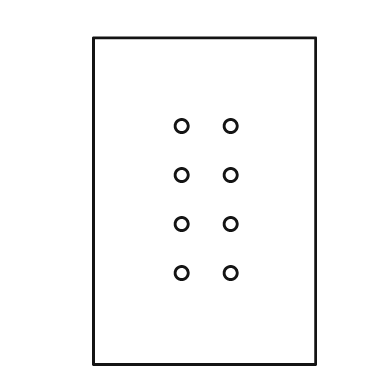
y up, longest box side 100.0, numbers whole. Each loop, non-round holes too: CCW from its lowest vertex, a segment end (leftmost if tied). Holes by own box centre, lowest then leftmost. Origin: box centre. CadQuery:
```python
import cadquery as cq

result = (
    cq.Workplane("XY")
    .moveTo(-34.0, -50.0)
    .lineTo(34.0, -50.0)
    .lineTo(34.0, 50.0)
    .lineTo(-34.0, 50.0)
    .close()
    .moveTo(-7.0, -22.0)
    .circle(2.0)
    .moveTo(8.0, -22.0)
    .circle(2.0)
    .moveTo(-7.0, -7.0)
    .circle(2.0)
    .moveTo(8.0, -7.0)
    .circle(2.0)
    .moveTo(-7.0, 8.0)
    .circle(2.0)
    .moveTo(8.0, 8.0)
    .circle(2.0)
    .moveTo(-7.0, 23.0)
    .circle(2.0)
    .moveTo(8.0, 23.0)
    .circle(2.0)
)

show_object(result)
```